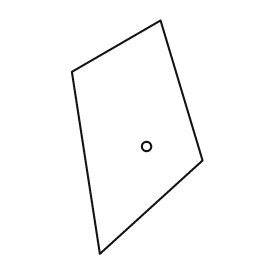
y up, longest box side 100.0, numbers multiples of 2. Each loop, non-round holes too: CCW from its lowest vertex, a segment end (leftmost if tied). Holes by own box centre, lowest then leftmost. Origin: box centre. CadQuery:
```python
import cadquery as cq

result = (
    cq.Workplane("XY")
    .moveTo(-16.0, -50.0)
    .lineTo(28.0, -10.0)
    .lineTo(10.0, 50.0)
    .lineTo(-28.0, 28.0)
    .close()
    .moveTo(4.0, -4.0)
    .circle(2.0)
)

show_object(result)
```